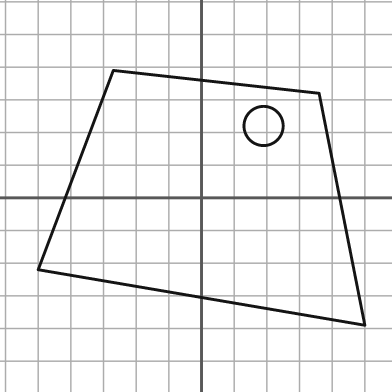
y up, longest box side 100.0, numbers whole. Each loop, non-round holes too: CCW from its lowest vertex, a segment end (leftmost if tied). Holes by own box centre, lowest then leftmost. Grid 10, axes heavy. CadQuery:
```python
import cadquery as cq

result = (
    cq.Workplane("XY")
    .moveTo(50.0, -39.0)
    .lineTo(36.0, 32.0)
    .lineTo(-27.0, 39.0)
    .lineTo(-50.0, -22.0)
    .close()
    .moveTo(19.0, 22.0)
    .circle(6.0)
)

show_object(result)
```